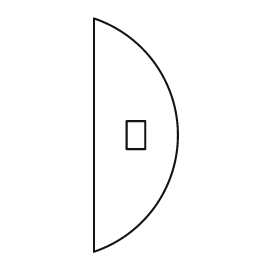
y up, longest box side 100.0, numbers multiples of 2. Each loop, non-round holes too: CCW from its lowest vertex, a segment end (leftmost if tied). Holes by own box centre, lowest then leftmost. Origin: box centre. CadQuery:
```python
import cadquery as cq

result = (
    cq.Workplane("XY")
    .moveTo(-18.0, -50.0)
    .threePointArc((18.0, 0.0), (-18.0, 50.0))
    .close()
    .moveTo(-4.0, -6.0)
    .lineTo(4.0, -6.0)
    .lineTo(4.0, 6.0)
    .lineTo(-4.0, 6.0)
    .close()
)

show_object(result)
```